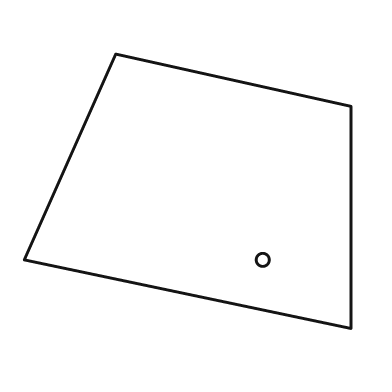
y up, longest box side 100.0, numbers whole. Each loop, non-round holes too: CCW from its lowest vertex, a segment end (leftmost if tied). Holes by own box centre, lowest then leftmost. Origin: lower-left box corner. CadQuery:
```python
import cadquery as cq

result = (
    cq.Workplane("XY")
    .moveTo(100.0, 0.0)
    .lineTo(100.0, 68.0)
    .lineTo(28.0, 84.0)
    .lineTo(0.0, 21.0)
    .close()
    .moveTo(73.0, 21.0)
    .circle(2.0)
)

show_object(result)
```